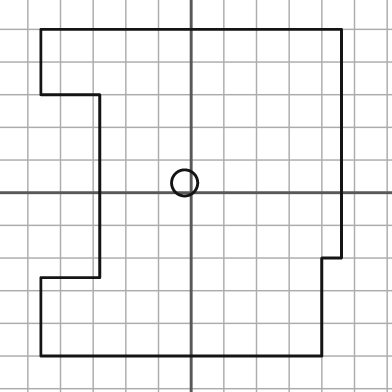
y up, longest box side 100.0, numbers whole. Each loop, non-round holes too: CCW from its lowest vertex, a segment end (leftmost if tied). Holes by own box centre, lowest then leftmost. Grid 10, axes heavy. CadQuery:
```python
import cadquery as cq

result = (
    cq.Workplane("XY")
    .moveTo(-46.0, -50.0)
    .lineTo(40.0, -50.0)
    .lineTo(40.0, -20.0)
    .lineTo(46.0, -20.0)
    .lineTo(46.0, 50.0)
    .lineTo(-46.0, 50.0)
    .lineTo(-46.0, 30.0)
    .lineTo(-28.0, 30.0)
    .lineTo(-28.0, -26.0)
    .lineTo(-46.0, -26.0)
    .close()
    .moveTo(-2.0, 3.0)
    .circle(4.0)
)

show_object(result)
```